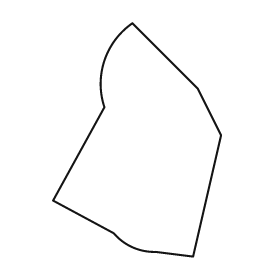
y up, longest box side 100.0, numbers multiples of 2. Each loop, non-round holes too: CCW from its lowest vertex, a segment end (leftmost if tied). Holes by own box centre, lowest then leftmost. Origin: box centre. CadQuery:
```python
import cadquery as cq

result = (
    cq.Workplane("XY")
    .moveTo(24.0, -50.0)
    .lineTo(36.0, 2.0)
    .lineTo(26.0, 22.0)
    .lineTo(-2.0, 50.0)
    .threePointArc((-14.0, 34.0), (-14.0, 14.0))
    .lineTo(-36.0, -26.0)
    .lineTo(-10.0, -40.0)
    .threePointArc((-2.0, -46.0), (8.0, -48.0))
    .close()
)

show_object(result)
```